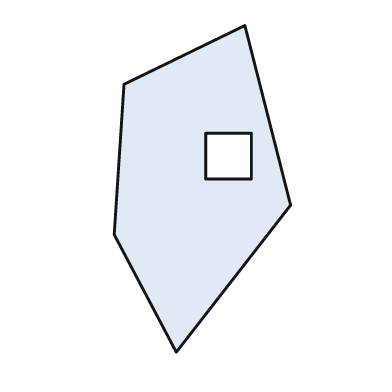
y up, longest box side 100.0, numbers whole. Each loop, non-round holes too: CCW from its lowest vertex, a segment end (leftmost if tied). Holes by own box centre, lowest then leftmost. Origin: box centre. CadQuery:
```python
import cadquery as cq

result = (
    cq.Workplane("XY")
    .moveTo(-8.0, -50.0)
    .lineTo(27.0, -5.0)
    .lineTo(13.0, 50.0)
    .lineTo(-24.0, 32.0)
    .lineTo(-27.0, -14.0)
    .close()
    .moveTo(1.0, 3.0)
    .lineTo(15.0, 3.0)
    .lineTo(15.0, 17.0)
    .lineTo(1.0, 17.0)
    .close()
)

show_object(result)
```